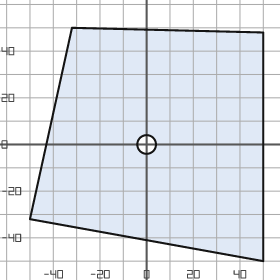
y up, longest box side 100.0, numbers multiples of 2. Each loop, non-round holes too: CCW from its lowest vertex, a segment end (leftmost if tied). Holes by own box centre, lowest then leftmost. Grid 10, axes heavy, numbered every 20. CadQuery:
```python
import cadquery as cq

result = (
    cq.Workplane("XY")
    .moveTo(50.0, -50.0)
    .lineTo(50.0, 48.0)
    .lineTo(-32.0, 50.0)
    .lineTo(-50.0, -32.0)
    .close()
    .moveTo(0.0, 0.0)
    .circle(4.0)
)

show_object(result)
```